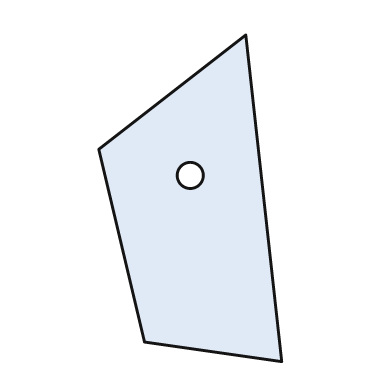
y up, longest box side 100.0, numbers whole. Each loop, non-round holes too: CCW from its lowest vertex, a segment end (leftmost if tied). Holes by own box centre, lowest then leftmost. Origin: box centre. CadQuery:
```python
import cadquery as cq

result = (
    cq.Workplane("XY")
    .moveTo(28.0, -50.0)
    .lineTo(17.0, 50.0)
    .lineTo(-28.0, 15.0)
    .lineTo(-14.0, -44.0)
    .close()
    .moveTo(0.0, 7.0)
    .circle(4.0)
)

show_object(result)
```